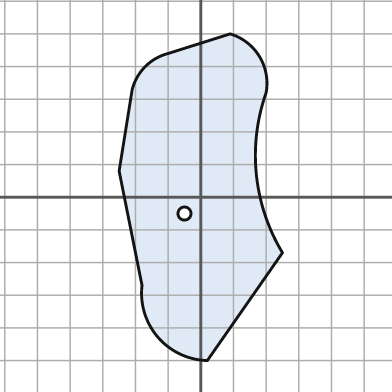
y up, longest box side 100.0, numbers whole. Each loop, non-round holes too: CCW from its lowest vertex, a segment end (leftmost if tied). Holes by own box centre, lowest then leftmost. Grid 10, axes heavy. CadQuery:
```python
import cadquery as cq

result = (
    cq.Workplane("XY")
    .moveTo(2.0, -50.0)
    .lineTo(25.0, -17.0)
    .threePointArc((17.0, 7.0), (20.0, 32.0))
    .threePointArc((18.0, 43.0), (9.0, 50.0))
    .lineTo(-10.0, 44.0)
    .threePointArc((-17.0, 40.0), (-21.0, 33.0))
    .lineTo(-25.0, 8.0)
    .lineTo(-18.0, -27.0)
    .threePointArc((-13.0, -43.0), (2.0, -50.0))
    .close()
    .moveTo(-5.0, -5.0)
    .circle(2.0)
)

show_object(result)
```